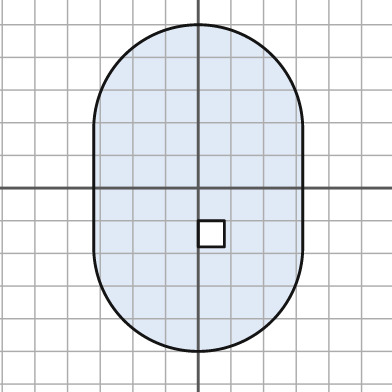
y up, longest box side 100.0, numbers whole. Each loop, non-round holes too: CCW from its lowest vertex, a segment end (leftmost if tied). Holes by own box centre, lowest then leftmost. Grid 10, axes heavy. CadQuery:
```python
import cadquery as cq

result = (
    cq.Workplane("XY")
    .moveTo(-32.0, -18.0)
    .threePointArc((0.0, -50.0), (32.0, -18.0))
    .lineTo(32.0, 18.0)
    .threePointArc((0.0, 50.0), (-32.0, 18.0))
    .close()
    .moveTo(0.0, -18.0)
    .lineTo(8.0, -18.0)
    .lineTo(8.0, -10.0)
    .lineTo(0.0, -10.0)
    .close()
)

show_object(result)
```